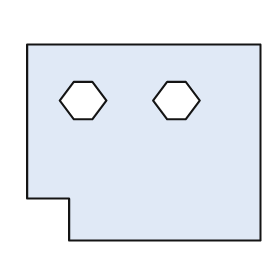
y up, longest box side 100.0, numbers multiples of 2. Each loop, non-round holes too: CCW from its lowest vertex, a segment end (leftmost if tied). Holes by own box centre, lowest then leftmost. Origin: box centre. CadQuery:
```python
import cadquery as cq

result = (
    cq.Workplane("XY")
    .moveTo(-32.0, -42.0)
    .lineTo(50.0, -42.0)
    .lineTo(50.0, 42.0)
    .lineTo(-50.0, 42.0)
    .lineTo(-50.0, -24.0)
    .lineTo(-32.0, -24.0)
    .close()
    .moveTo(-30.0, 10.0)
    .lineTo(-22.0, 10.0)
    .lineTo(-16.0, 18.0)
    .lineTo(-22.0, 26.0)
    .lineTo(-30.0, 26.0)
    .lineTo(-36.0, 18.0)
    .close()
    .moveTo(10.0, 10.0)
    .lineTo(18.0, 10.0)
    .lineTo(24.0, 18.0)
    .lineTo(18.0, 26.0)
    .lineTo(10.0, 26.0)
    .lineTo(4.0, 18.0)
    .close()
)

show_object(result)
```